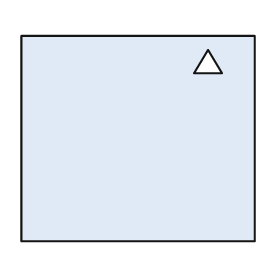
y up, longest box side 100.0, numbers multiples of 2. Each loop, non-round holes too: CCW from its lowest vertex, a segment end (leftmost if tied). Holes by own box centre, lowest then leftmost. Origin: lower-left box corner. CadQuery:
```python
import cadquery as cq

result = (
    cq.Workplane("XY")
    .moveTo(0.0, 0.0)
    .lineTo(100.0, 0.0)
    .lineTo(100.0, 88.0)
    .lineTo(0.0, 88.0)
    .close()
    .moveTo(74.0, 72.0)
    .lineTo(86.0, 72.0)
    .lineTo(80.0, 82.0)
    .close()
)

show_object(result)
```